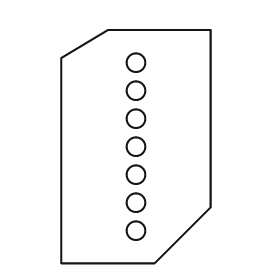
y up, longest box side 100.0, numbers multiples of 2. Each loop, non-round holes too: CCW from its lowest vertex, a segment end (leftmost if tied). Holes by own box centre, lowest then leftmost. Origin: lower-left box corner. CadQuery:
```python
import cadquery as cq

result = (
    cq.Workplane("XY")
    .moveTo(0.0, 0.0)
    .lineTo(40.0, 0.0)
    .lineTo(64.0, 24.0)
    .lineTo(64.0, 100.0)
    .lineTo(20.0, 100.0)
    .lineTo(0.0, 88.0)
    .close()
    .moveTo(32.0, 14.0)
    .circle(4.0)
    .moveTo(32.0, 26.0)
    .circle(4.0)
    .moveTo(32.0, 38.0)
    .circle(4.0)
    .moveTo(32.0, 50.0)
    .circle(4.0)
    .moveTo(32.0, 62.0)
    .circle(4.0)
    .moveTo(32.0, 74.0)
    .circle(4.0)
    .moveTo(32.0, 86.0)
    .circle(4.0)
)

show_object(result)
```